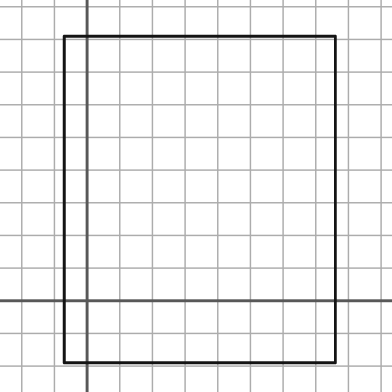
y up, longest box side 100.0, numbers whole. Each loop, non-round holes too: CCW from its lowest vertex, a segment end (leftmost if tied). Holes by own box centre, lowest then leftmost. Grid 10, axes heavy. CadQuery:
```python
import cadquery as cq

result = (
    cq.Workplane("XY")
    .moveTo(-7.0, -19.0)
    .lineTo(76.0, -19.0)
    .lineTo(76.0, 81.0)
    .lineTo(-7.0, 81.0)
    .close()
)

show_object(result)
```